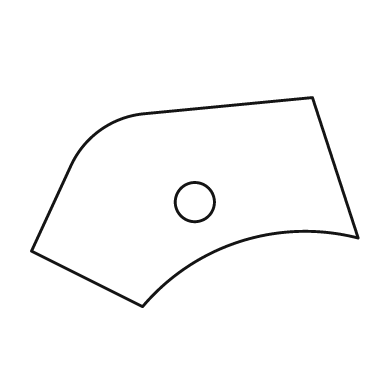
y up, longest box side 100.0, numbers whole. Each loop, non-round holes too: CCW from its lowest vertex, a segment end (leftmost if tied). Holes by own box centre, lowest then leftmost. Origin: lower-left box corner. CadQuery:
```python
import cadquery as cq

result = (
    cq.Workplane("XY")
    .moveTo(34.0, 0.0)
    .threePointArc((64.0, 20.0), (100.0, 21.0))
    .lineTo(86.0, 64.0)
    .lineTo(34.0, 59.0)
    .threePointArc((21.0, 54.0), (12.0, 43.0))
    .lineTo(0.0, 17.0)
    .close()
    .moveTo(50.0, 32.0)
    .circle(6.0)
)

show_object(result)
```